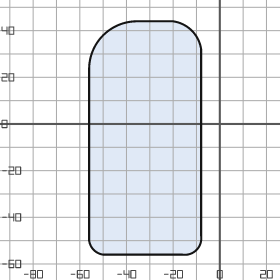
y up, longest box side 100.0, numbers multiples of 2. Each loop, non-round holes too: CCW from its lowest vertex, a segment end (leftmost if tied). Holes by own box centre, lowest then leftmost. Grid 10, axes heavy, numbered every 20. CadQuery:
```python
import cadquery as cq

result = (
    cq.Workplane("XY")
    .moveTo(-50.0, -56.0)
    .lineTo(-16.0, -56.0)
    .threePointArc((-10.0, -54.0), (-8.0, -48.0))
    .lineTo(-8.0, 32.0)
    .threePointArc((-12.0, 40.0), (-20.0, 44.0))
    .lineTo(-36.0, 44.0)
    .threePointArc((-50.0, 38.0), (-56.0, 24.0))
    .lineTo(-56.0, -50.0)
    .threePointArc((-54.0, -54.0), (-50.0, -56.0))
    .close()
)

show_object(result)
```